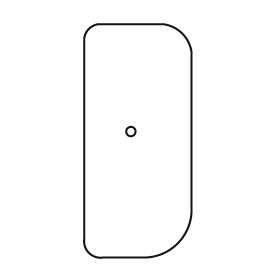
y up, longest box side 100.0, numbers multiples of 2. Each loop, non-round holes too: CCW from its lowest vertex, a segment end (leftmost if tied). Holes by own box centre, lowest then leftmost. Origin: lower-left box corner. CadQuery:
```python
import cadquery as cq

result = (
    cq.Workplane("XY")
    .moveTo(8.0, 0.0)
    .lineTo(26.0, 0.0)
    .threePointArc((40.0, 6.0), (46.0, 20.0))
    .lineTo(46.0, 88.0)
    .threePointArc((42.0, 96.0), (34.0, 100.0))
    .lineTo(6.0, 100.0)
    .threePointArc((2.0, 98.0), (0.0, 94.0))
    .lineTo(0.0, 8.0)
    .threePointArc((2.0, 2.0), (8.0, 0.0))
    .close()
    .moveTo(20.0, 54.0)
    .circle(2.0)
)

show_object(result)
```